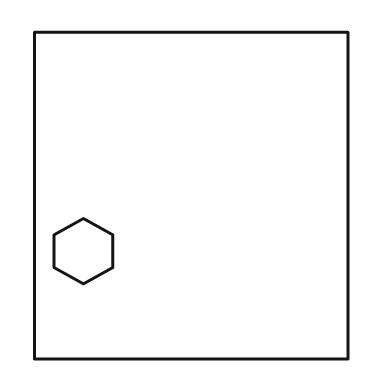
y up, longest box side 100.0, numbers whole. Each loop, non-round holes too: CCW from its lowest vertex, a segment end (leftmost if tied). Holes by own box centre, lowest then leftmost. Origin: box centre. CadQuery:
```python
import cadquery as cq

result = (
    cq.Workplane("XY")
    .moveTo(-48.0, -50.0)
    .lineTo(48.0, -50.0)
    .lineTo(48.0, 50.0)
    .lineTo(-48.0, 50.0)
    .close()
    .moveTo(-33.0, -27.0)
    .lineTo(-24.0, -22.0)
    .lineTo(-24.0, -12.0)
    .lineTo(-33.0, -7.0)
    .lineTo(-42.0, -12.0)
    .lineTo(-42.0, -22.0)
    .close()
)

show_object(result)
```